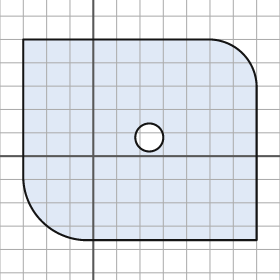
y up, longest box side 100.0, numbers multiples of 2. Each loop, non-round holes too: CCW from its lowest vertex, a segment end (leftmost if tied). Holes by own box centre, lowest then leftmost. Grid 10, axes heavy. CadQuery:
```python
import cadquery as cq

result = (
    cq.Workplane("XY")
    .moveTo(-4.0, -36.0)
    .lineTo(70.0, -36.0)
    .lineTo(70.0, 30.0)
    .threePointArc((64.0, 44.0), (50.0, 50.0))
    .lineTo(-30.0, 50.0)
    .lineTo(-30.0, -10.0)
    .threePointArc((-22.0, -28.0), (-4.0, -36.0))
    .close()
    .moveTo(24.0, 8.0)
    .circle(6.0)
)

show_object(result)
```